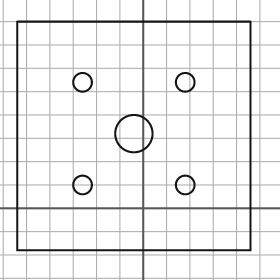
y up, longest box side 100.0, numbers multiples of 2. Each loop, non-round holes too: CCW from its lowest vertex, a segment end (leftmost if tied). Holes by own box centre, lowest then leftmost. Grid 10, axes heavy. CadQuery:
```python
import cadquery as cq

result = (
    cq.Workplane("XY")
    .moveTo(-54.0, -18.0)
    .lineTo(46.0, -18.0)
    .lineTo(46.0, 80.0)
    .lineTo(-54.0, 80.0)
    .close()
    .moveTo(-26.0, 10.0)
    .circle(4.0)
    .moveTo(18.0, 10.0)
    .circle(4.0)
    .moveTo(-4.0, 32.0)
    .circle(8.0)
    .moveTo(-26.0, 54.0)
    .circle(4.0)
    .moveTo(18.0, 54.0)
    .circle(4.0)
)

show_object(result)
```